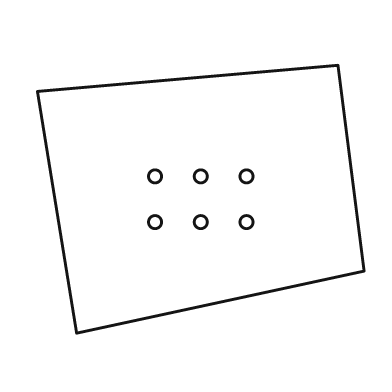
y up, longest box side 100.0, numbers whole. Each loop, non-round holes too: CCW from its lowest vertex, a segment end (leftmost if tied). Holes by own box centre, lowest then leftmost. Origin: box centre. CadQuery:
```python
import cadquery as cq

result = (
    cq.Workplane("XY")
    .moveTo(-38.0, -41.0)
    .lineTo(50.0, -22.0)
    .lineTo(42.0, 41.0)
    .lineTo(-50.0, 33.0)
    .close()
    .moveTo(-14.0, -7.0)
    .circle(2.0)
    .moveTo(0.0, -7.0)
    .circle(2.0)
    .moveTo(14.0, -7.0)
    .circle(2.0)
    .moveTo(-14.0, 7.0)
    .circle(2.0)
    .moveTo(0.0, 7.0)
    .circle(2.0)
    .moveTo(14.0, 7.0)
    .circle(2.0)
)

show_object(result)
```